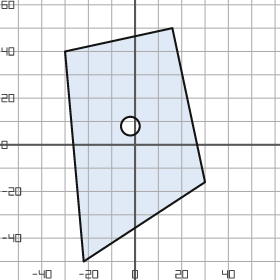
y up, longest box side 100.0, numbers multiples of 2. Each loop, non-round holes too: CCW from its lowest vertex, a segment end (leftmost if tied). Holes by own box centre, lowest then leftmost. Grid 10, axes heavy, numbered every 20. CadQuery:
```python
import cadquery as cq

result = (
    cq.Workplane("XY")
    .moveTo(-22.0, -50.0)
    .lineTo(30.0, -16.0)
    .lineTo(16.0, 50.0)
    .lineTo(-30.0, 40.0)
    .close()
    .moveTo(-2.0, 8.0)
    .circle(4.0)
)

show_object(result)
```